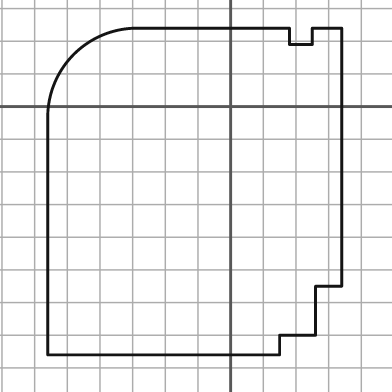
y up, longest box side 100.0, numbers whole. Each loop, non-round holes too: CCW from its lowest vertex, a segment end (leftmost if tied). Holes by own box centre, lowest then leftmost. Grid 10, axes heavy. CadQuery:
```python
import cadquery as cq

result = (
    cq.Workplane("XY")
    .moveTo(-56.0, -76.0)
    .lineTo(15.0, -76.0)
    .lineTo(15.0, -70.0)
    .lineTo(26.0, -70.0)
    .lineTo(26.0, -55.0)
    .lineTo(34.0, -55.0)
    .lineTo(34.0, 24.0)
    .lineTo(25.0, 24.0)
    .lineTo(25.0, 19.0)
    .lineTo(18.0, 19.0)
    .lineTo(18.0, 24.0)
    .lineTo(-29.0, 24.0)
    .threePointArc((-48.0, 16.0), (-56.0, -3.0))
    .close()
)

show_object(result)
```